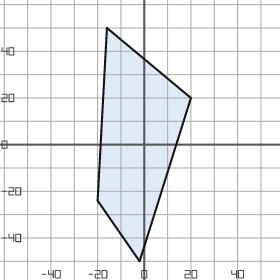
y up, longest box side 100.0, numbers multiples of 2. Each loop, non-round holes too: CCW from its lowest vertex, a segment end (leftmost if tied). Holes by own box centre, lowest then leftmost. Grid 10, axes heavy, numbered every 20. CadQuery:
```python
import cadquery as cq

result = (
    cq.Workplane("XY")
    .moveTo(-2.0, -50.0)
    .lineTo(20.0, 20.0)
    .lineTo(-16.0, 50.0)
    .lineTo(-20.0, -24.0)
    .close()
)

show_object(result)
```